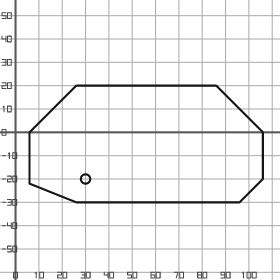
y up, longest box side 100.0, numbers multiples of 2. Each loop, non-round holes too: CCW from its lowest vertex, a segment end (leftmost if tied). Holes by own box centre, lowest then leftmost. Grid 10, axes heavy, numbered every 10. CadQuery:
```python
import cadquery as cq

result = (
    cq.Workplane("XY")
    .moveTo(26.0, -30.0)
    .lineTo(96.0, -30.0)
    .lineTo(106.0, -20.0)
    .lineTo(106.0, 0.0)
    .lineTo(86.0, 20.0)
    .lineTo(26.0, 20.0)
    .lineTo(6.0, 0.0)
    .lineTo(6.0, -22.0)
    .close()
    .moveTo(30.0, -20.0)
    .circle(2.0)
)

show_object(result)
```